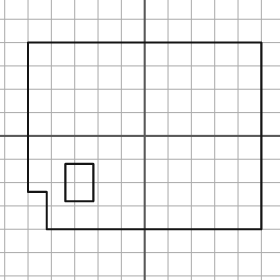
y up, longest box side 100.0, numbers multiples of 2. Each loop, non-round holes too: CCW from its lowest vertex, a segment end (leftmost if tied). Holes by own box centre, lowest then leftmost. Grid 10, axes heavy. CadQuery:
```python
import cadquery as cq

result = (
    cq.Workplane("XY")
    .moveTo(-42.0, -40.0)
    .lineTo(50.0, -40.0)
    .lineTo(50.0, 40.0)
    .lineTo(-50.0, 40.0)
    .lineTo(-50.0, -24.0)
    .lineTo(-42.0, -24.0)
    .close()
    .moveTo(-34.0, -28.0)
    .lineTo(-22.0, -28.0)
    .lineTo(-22.0, -12.0)
    .lineTo(-34.0, -12.0)
    .close()
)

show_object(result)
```